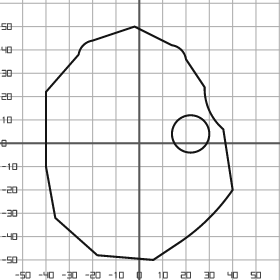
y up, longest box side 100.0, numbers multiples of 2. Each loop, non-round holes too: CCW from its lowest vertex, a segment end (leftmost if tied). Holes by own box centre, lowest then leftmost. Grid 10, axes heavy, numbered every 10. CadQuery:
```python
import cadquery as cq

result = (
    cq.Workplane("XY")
    .moveTo(6.0, -50.0)
    .lineTo(18.0, -42.0)
    .threePointArc((30.0, -32.0), (40.0, -20.0))
    .lineTo(36.0, 6.0)
    .threePointArc((30.0, 14.0), (28.0, 24.0))
    .lineTo(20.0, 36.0)
    .threePointArc((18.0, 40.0), (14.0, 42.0))
    .lineTo(-2.0, 50.0)
    .lineTo(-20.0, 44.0)
    .threePointArc((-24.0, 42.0), (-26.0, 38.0))
    .lineTo(-40.0, 22.0)
    .lineTo(-40.0, -10.0)
    .lineTo(-36.0, -32.0)
    .lineTo(-18.0, -48.0)
    .close()
    .moveTo(22.0, 4.0)
    .circle(8.0)
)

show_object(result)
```